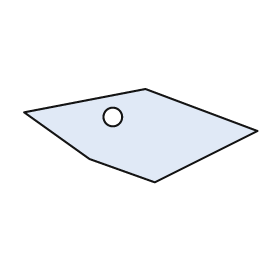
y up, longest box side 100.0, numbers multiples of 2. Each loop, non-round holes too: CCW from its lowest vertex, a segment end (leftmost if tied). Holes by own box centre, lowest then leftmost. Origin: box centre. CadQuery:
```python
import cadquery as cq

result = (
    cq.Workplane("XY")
    .moveTo(6.0, -20.0)
    .lineTo(50.0, 2.0)
    .lineTo(2.0, 20.0)
    .lineTo(-50.0, 10.0)
    .lineTo(-22.0, -10.0)
    .close()
    .moveTo(-12.0, 8.0)
    .circle(4.0)
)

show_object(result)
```